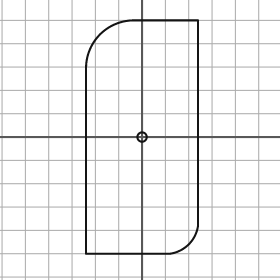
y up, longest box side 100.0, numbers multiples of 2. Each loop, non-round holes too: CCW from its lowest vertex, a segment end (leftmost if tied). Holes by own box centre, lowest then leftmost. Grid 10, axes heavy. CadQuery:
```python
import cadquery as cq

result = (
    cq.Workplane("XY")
    .moveTo(-24.0, -50.0)
    .lineTo(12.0, -50.0)
    .threePointArc((20.0, -46.0), (24.0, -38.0))
    .lineTo(24.0, 50.0)
    .lineTo(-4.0, 50.0)
    .threePointArc((-18.0, 44.0), (-24.0, 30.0))
    .close()
    .moveTo(0.0, 0.0)
    .circle(2.0)
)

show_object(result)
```